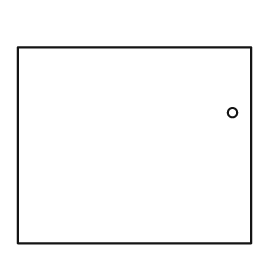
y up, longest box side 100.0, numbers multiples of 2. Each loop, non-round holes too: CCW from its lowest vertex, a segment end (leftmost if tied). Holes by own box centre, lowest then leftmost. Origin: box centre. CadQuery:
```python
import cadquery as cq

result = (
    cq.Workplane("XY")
    .moveTo(-50.0, -42.0)
    .lineTo(50.0, -42.0)
    .lineTo(50.0, 42.0)
    .lineTo(-50.0, 42.0)
    .close()
    .moveTo(42.0, 14.0)
    .circle(2.0)
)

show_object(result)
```